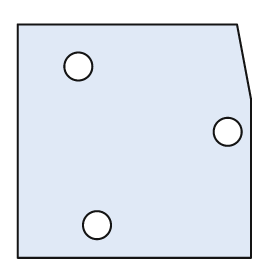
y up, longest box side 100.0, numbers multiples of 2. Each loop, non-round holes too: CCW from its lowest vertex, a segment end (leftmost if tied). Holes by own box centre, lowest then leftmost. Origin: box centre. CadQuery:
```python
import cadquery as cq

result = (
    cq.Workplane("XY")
    .moveTo(-50.0, -50.0)
    .lineTo(50.0, -50.0)
    .lineTo(50.0, 18.0)
    .lineTo(44.0, 50.0)
    .lineTo(-50.0, 50.0)
    .close()
    .moveTo(-16.0, -36.0)
    .circle(6.0)
    .moveTo(40.0, 4.0)
    .circle(6.0)
    .moveTo(-24.0, 32.0)
    .circle(6.0)
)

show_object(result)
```